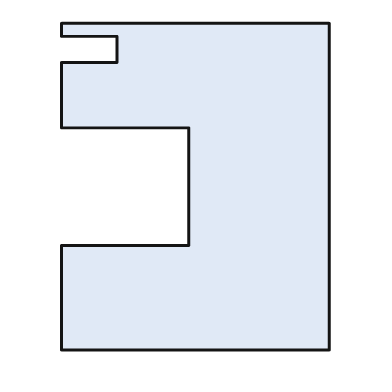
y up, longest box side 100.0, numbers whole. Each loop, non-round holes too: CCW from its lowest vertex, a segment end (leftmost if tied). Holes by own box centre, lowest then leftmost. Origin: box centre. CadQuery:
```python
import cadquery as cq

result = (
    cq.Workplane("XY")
    .moveTo(-41.0, -50.0)
    .lineTo(41.0, -50.0)
    .lineTo(41.0, 50.0)
    .lineTo(-41.0, 50.0)
    .lineTo(-41.0, 46.0)
    .lineTo(-24.0, 46.0)
    .lineTo(-24.0, 38.0)
    .lineTo(-41.0, 38.0)
    .lineTo(-41.0, 18.0)
    .lineTo(-2.0, 18.0)
    .lineTo(-2.0, -18.0)
    .lineTo(-41.0, -18.0)
    .close()
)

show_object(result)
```